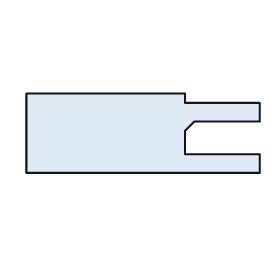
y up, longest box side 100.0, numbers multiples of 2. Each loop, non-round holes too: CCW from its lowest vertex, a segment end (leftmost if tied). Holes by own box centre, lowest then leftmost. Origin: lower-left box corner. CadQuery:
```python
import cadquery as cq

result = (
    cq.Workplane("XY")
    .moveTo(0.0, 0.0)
    .lineTo(100.0, 0.0)
    .lineTo(100.0, 8.0)
    .lineTo(68.0, 8.0)
    .lineTo(68.0, 18.0)
    .lineTo(72.0, 22.0)
    .lineTo(100.0, 22.0)
    .lineTo(100.0, 30.0)
    .lineTo(68.0, 30.0)
    .lineTo(68.0, 34.0)
    .lineTo(0.0, 34.0)
    .close()
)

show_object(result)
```